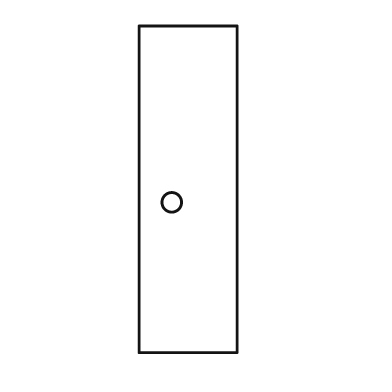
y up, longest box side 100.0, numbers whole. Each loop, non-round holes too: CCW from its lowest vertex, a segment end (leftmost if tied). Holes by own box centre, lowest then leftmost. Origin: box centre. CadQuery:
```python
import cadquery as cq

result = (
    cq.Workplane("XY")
    .moveTo(-15.0, -50.0)
    .lineTo(15.0, -50.0)
    .lineTo(15.0, 50.0)
    .lineTo(-15.0, 50.0)
    .close()
    .moveTo(-5.0, -4.0)
    .circle(3.0)
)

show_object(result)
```